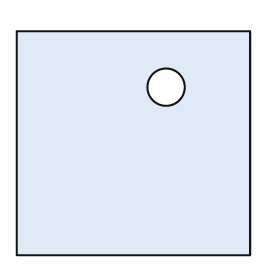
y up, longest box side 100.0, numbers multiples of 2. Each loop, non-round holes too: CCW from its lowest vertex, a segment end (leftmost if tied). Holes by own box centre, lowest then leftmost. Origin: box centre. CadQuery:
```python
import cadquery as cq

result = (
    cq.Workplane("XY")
    .moveTo(-50.0, -48.0)
    .lineTo(50.0, -48.0)
    .lineTo(50.0, 48.0)
    .lineTo(-50.0, 48.0)
    .close()
    .moveTo(14.0, 24.0)
    .circle(8.0)
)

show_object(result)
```